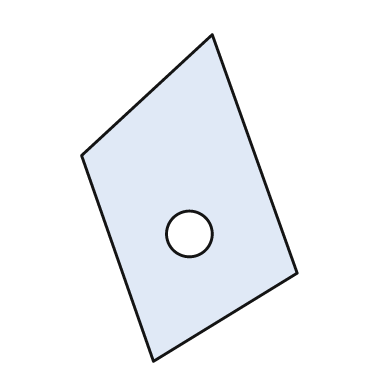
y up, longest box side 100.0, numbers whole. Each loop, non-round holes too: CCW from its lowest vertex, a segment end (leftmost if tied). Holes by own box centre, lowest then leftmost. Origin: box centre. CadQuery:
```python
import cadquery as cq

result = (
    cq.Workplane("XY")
    .moveTo(-11.0, -50.0)
    .lineTo(33.0, -23.0)
    .lineTo(7.0, 50.0)
    .lineTo(-33.0, 13.0)
    .close()
    .moveTo(0.0, -11.0)
    .circle(7.0)
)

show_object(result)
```